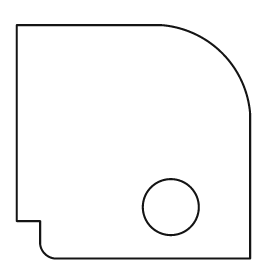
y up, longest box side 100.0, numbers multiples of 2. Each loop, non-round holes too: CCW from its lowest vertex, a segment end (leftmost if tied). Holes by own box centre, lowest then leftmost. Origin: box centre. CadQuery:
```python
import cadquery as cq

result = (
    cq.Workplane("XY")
    .moveTo(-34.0, -50.0)
    .lineTo(50.0, -50.0)
    .lineTo(50.0, 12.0)
    .threePointArc((38.0, 38.0), (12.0, 50.0))
    .lineTo(-50.0, 50.0)
    .lineTo(-50.0, -34.0)
    .lineTo(-40.0, -34.0)
    .lineTo(-40.0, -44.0)
    .threePointArc((-38.0, -48.0), (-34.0, -50.0))
    .close()
    .moveTo(16.0, -28.0)
    .circle(12.0)
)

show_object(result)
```